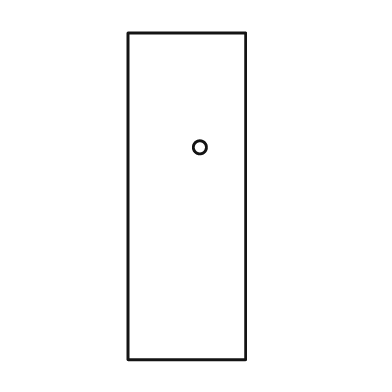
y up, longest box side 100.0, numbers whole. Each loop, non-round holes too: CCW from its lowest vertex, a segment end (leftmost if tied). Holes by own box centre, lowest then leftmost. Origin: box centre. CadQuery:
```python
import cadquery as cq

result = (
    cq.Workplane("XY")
    .moveTo(-18.0, -50.0)
    .lineTo(18.0, -50.0)
    .lineTo(18.0, 50.0)
    .lineTo(-18.0, 50.0)
    .close()
    .moveTo(4.0, 15.0)
    .circle(2.0)
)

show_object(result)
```